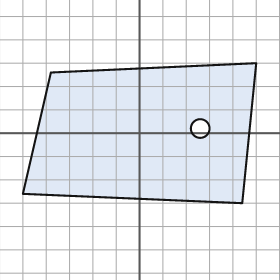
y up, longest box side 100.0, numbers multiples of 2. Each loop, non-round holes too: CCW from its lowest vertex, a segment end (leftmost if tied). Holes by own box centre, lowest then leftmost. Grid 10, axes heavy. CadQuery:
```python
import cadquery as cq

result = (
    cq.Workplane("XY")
    .moveTo(44.0, -30.0)
    .lineTo(50.0, 30.0)
    .lineTo(-38.0, 26.0)
    .lineTo(-50.0, -26.0)
    .close()
    .moveTo(26.0, 2.0)
    .circle(4.0)
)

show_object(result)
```